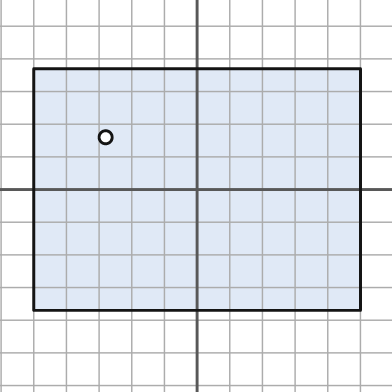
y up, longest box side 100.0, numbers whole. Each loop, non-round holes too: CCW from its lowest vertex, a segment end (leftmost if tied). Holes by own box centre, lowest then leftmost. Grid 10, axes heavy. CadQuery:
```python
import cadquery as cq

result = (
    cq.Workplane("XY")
    .moveTo(-50.0, -37.0)
    .lineTo(50.0, -37.0)
    .lineTo(50.0, 37.0)
    .lineTo(-50.0, 37.0)
    .close()
    .moveTo(-28.0, 16.0)
    .circle(2.0)
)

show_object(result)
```